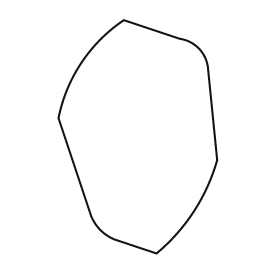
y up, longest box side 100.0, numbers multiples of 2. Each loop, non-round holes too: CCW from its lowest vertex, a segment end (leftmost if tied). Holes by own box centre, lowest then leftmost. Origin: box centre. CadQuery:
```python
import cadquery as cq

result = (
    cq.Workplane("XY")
    .moveTo(8.0, -50.0)
    .threePointArc((24.0, -32.0), (34.0, -10.0))
    .lineTo(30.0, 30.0)
    .threePointArc((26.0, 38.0), (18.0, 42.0))
    .lineTo(-6.0, 50.0)
    .threePointArc((-24.0, 32.0), (-34.0, 8.0))
    .lineTo(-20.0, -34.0)
    .threePointArc((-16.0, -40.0), (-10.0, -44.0))
    .close()
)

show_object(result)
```